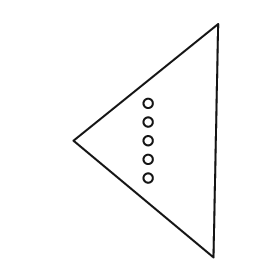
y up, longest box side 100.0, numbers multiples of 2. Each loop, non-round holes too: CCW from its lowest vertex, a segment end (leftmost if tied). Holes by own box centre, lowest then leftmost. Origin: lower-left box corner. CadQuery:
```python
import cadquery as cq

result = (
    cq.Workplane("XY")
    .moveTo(60.0, 0.0)
    .lineTo(62.0, 100.0)
    .lineTo(0.0, 50.0)
    .close()
    .moveTo(32.0, 34.0)
    .circle(2.0)
    .moveTo(32.0, 42.0)
    .circle(2.0)
    .moveTo(32.0, 50.0)
    .circle(2.0)
    .moveTo(32.0, 58.0)
    .circle(2.0)
    .moveTo(32.0, 66.0)
    .circle(2.0)
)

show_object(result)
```